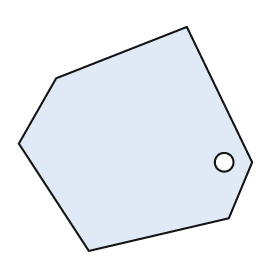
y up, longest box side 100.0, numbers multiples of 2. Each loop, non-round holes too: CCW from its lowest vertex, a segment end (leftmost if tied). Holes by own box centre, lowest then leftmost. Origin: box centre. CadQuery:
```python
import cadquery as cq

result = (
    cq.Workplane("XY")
    .moveTo(-20.0, -48.0)
    .lineTo(40.0, -34.0)
    .lineTo(50.0, -10.0)
    .lineTo(22.0, 48.0)
    .lineTo(-34.0, 26.0)
    .lineTo(-50.0, -2.0)
    .close()
    .moveTo(38.0, -10.0)
    .circle(4.0)
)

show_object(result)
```